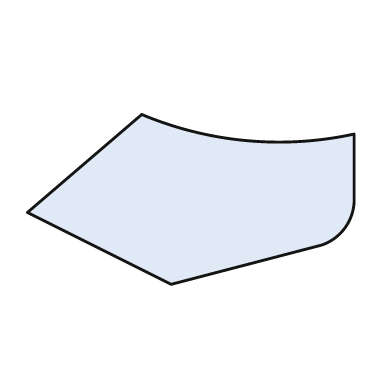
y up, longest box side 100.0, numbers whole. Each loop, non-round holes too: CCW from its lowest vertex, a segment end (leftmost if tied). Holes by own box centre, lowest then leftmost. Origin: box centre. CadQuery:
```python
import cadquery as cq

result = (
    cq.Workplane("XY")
    .moveTo(-6.0, -26.0)
    .lineTo(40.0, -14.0)
    .threePointArc((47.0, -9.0), (50.0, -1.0))
    .lineTo(50.0, 20.0)
    .threePointArc((17.0, 18.0), (-15.0, 26.0))
    .lineTo(-50.0, -4.0)
    .close()
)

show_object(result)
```